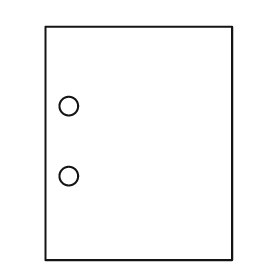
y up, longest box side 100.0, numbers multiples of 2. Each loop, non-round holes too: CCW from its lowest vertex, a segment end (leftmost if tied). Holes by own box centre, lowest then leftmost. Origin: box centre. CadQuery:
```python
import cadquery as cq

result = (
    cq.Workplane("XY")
    .moveTo(-40.0, -50.0)
    .lineTo(40.0, -50.0)
    .lineTo(40.0, 50.0)
    .lineTo(-40.0, 50.0)
    .close()
    .moveTo(-30.0, -14.0)
    .circle(4.0)
    .moveTo(-30.0, 16.0)
    .circle(4.0)
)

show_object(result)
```